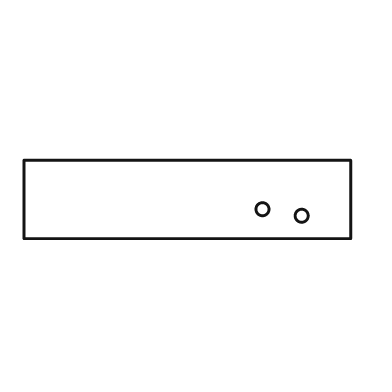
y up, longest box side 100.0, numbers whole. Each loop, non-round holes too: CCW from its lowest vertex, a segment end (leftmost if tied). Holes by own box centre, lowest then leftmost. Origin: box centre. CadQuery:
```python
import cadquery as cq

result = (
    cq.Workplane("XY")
    .moveTo(-50.0, -12.0)
    .lineTo(50.0, -12.0)
    .lineTo(50.0, 12.0)
    .lineTo(-50.0, 12.0)
    .close()
    .moveTo(35.0, -5.0)
    .circle(2.0)
    .moveTo(23.0, -3.0)
    .circle(2.0)
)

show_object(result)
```